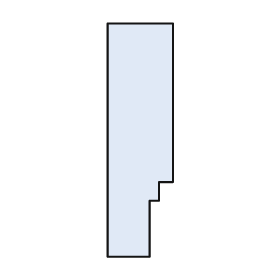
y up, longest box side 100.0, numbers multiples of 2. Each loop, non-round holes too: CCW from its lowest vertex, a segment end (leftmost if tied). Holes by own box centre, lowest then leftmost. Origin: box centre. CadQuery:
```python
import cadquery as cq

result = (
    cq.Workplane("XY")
    .moveTo(-14.0, -50.0)
    .lineTo(4.0, -50.0)
    .lineTo(4.0, -26.0)
    .lineTo(8.0, -26.0)
    .lineTo(8.0, -18.0)
    .lineTo(14.0, -18.0)
    .lineTo(14.0, 50.0)
    .lineTo(-14.0, 50.0)
    .close()
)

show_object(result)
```